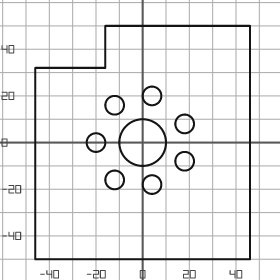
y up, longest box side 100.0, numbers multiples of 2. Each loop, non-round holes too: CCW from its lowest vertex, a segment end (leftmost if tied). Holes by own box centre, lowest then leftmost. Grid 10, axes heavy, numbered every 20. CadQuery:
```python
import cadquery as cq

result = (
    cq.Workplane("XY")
    .moveTo(-46.0, -50.0)
    .lineTo(46.0, -50.0)
    .lineTo(46.0, 50.0)
    .lineTo(-16.0, 50.0)
    .lineTo(-16.0, 32.0)
    .lineTo(-46.0, 32.0)
    .close()
    .moveTo(4.0, -18.0)
    .circle(4.0)
    .moveTo(-12.0, -16.0)
    .circle(4.0)
    .moveTo(18.0, -8.0)
    .circle(4.0)
    .moveTo(-20.0, 0.0)
    .circle(4.0)
    .moveTo(0.0, 0.0)
    .circle(10.0)
    .moveTo(18.0, 8.0)
    .circle(4.0)
    .moveTo(-12.0, 16.0)
    .circle(4.0)
    .moveTo(4.0, 20.0)
    .circle(4.0)
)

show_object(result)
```